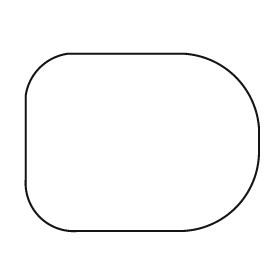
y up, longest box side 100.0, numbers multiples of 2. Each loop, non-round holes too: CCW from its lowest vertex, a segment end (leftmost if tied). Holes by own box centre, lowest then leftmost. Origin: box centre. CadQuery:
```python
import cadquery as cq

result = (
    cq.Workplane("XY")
    .moveTo(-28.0, -38.0)
    .lineTo(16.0, -38.0)
    .threePointArc((40.0, -28.0), (50.0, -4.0))
    .lineTo(50.0, 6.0)
    .threePointArc((40.0, 28.0), (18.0, 38.0))
    .lineTo(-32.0, 38.0)
    .threePointArc((-44.0, 32.0), (-50.0, 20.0))
    .lineTo(-50.0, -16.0)
    .threePointArc((-44.0, -32.0), (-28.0, -38.0))
    .close()
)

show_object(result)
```